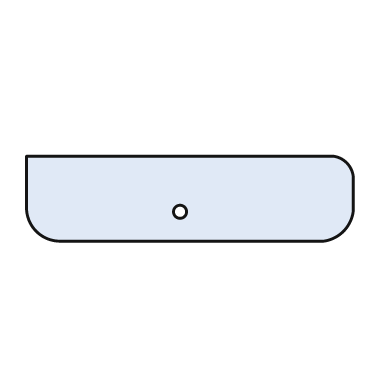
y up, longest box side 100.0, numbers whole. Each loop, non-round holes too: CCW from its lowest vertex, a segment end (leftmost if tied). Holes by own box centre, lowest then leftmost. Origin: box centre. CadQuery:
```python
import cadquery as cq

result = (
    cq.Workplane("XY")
    .moveTo(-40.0, -13.0)
    .lineTo(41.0, -13.0)
    .threePointArc((47.0, -10.0), (50.0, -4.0))
    .lineTo(50.0, 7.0)
    .threePointArc((48.0, 11.0), (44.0, 13.0))
    .lineTo(-50.0, 13.0)
    .lineTo(-50.0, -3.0)
    .threePointArc((-47.0, -10.0), (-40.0, -13.0))
    .close()
    .moveTo(-3.0, -4.0)
    .circle(2.0)
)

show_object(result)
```